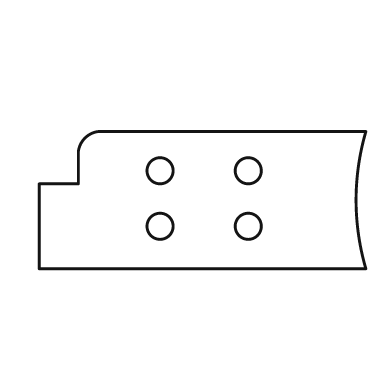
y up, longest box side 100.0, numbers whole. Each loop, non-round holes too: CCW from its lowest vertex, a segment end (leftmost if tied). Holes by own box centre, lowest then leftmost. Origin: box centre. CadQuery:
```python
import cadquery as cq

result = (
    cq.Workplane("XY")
    .moveTo(-50.0, -21.0)
    .lineTo(50.0, -21.0)
    .threePointArc((47.0, 0.0), (50.0, 21.0))
    .lineTo(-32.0, 21.0)
    .threePointArc((-36.0, 19.0), (-38.0, 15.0))
    .lineTo(-38.0, 5.0)
    .lineTo(-50.0, 5.0)
    .close()
    .moveTo(-13.0, -8.0)
    .circle(4.0)
    .moveTo(14.0, -8.0)
    .circle(4.0)
    .moveTo(-13.0, 9.0)
    .circle(4.0)
    .moveTo(14.0, 9.0)
    .circle(4.0)
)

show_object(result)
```